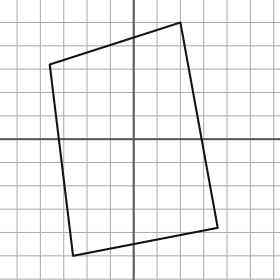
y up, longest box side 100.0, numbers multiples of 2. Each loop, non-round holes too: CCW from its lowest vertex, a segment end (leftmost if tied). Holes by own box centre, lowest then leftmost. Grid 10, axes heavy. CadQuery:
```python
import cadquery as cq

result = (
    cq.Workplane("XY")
    .moveTo(-26.0, -50.0)
    .lineTo(36.0, -38.0)
    .lineTo(20.0, 50.0)
    .lineTo(-36.0, 32.0)
    .close()
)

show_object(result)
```